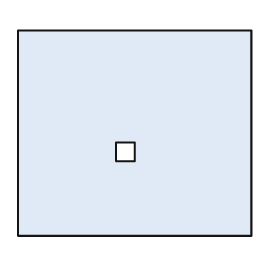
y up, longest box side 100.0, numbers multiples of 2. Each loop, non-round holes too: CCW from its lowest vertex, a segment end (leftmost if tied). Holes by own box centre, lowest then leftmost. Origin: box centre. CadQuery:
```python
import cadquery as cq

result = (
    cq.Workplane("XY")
    .moveTo(-50.0, -44.0)
    .lineTo(50.0, -44.0)
    .lineTo(50.0, 44.0)
    .lineTo(-50.0, 44.0)
    .close()
    .moveTo(-8.0, -12.0)
    .lineTo(0.0, -12.0)
    .lineTo(0.0, -4.0)
    .lineTo(-8.0, -4.0)
    .close()
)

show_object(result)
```